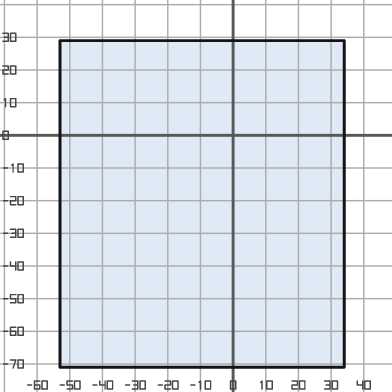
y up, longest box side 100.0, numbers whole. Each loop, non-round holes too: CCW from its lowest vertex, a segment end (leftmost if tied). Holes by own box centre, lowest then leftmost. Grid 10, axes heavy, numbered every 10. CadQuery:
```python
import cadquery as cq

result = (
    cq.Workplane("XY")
    .moveTo(-53.0, -71.0)
    .lineTo(34.0, -71.0)
    .lineTo(34.0, 29.0)
    .lineTo(-53.0, 29.0)
    .close()
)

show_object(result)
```